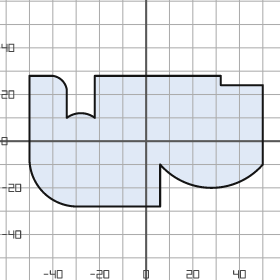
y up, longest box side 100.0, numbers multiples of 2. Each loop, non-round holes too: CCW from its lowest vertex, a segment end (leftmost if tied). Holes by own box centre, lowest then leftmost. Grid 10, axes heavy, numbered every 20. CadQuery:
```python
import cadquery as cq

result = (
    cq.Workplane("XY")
    .moveTo(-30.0, -28.0)
    .lineTo(6.0, -28.0)
    .lineTo(6.0, -10.0)
    .threePointArc((28.0, -20.0), (50.0, -10.0))
    .lineTo(50.0, 24.0)
    .lineTo(32.0, 24.0)
    .lineTo(32.0, 28.0)
    .lineTo(-22.0, 28.0)
    .lineTo(-22.0, 10.0)
    .threePointArc((-28.0, 12.0), (-34.0, 10.0))
    .lineTo(-34.0, 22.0)
    .threePointArc((-36.0, 26.0), (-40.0, 28.0))
    .lineTo(-50.0, 28.0)
    .lineTo(-50.0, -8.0)
    .threePointArc((-44.0, -22.0), (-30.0, -28.0))
    .close()
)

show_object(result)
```